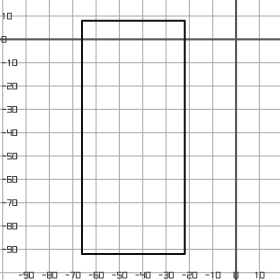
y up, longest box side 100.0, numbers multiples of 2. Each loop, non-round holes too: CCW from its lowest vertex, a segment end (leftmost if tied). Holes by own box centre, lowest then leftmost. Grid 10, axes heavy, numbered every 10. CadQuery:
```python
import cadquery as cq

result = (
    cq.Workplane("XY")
    .moveTo(-66.0, -92.0)
    .lineTo(-22.0, -92.0)
    .lineTo(-22.0, 8.0)
    .lineTo(-66.0, 8.0)
    .close()
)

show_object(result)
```